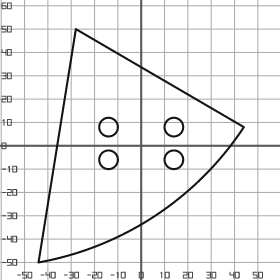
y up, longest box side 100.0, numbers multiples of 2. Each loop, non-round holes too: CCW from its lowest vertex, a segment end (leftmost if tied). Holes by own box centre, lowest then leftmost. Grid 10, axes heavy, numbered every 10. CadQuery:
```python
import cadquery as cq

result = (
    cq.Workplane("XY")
    .moveTo(-44.0, -50.0)
    .threePointArc((6.0, -30.0), (44.0, 8.0))
    .lineTo(-28.0, 50.0)
    .close()
    .moveTo(-14.0, -6.0)
    .circle(4.0)
    .moveTo(14.0, -6.0)
    .circle(4.0)
    .moveTo(-14.0, 8.0)
    .circle(4.0)
    .moveTo(14.0, 8.0)
    .circle(4.0)
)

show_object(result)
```